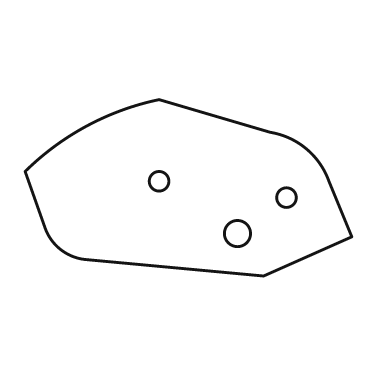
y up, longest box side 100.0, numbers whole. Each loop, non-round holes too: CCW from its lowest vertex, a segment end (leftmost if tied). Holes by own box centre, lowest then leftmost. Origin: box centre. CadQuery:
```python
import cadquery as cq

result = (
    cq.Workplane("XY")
    .moveTo(23.0, -27.0)
    .lineTo(50.0, -15.0)
    .lineTo(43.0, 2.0)
    .threePointArc((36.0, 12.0), (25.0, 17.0))
    .lineTo(-9.0, 27.0)
    .threePointArc((-31.0, 19.0), (-50.0, 5.0))
    .lineTo(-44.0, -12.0)
    .threePointArc((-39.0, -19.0), (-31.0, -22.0))
    .close()
    .moveTo(15.0, -14.0)
    .circle(4.0)
    .moveTo(30.0, -3.0)
    .circle(3.0)
    .moveTo(-9.0, 2.0)
    .circle(3.0)
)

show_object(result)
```